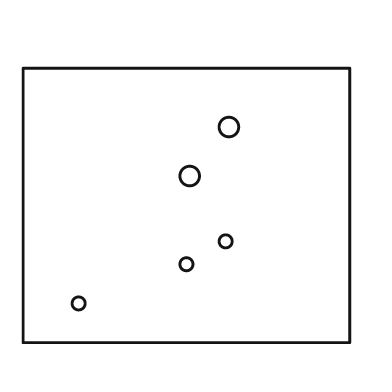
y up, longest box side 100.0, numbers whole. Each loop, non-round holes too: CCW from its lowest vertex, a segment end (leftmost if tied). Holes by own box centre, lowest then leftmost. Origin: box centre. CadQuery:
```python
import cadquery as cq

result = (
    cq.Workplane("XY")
    .moveTo(-50.0, -42.0)
    .lineTo(50.0, -42.0)
    .lineTo(50.0, 42.0)
    .lineTo(-50.0, 42.0)
    .close()
    .moveTo(-33.0, -30.0)
    .circle(2.0)
    .moveTo(0.0, -18.0)
    .circle(2.0)
    .moveTo(12.0, -11.0)
    .circle(2.0)
    .moveTo(1.0, 9.0)
    .circle(3.0)
    .moveTo(13.0, 24.0)
    .circle(3.0)
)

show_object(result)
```